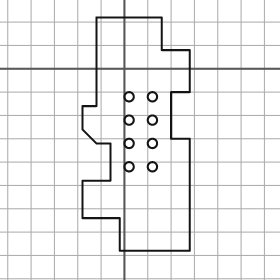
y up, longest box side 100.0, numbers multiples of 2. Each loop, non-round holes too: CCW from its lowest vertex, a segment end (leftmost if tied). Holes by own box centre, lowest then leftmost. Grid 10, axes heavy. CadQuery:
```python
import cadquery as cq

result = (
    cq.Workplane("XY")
    .moveTo(-2.0, -78.0)
    .lineTo(28.0, -78.0)
    .lineTo(28.0, -30.0)
    .lineTo(20.0, -30.0)
    .lineTo(20.0, -10.0)
    .lineTo(28.0, -10.0)
    .lineTo(28.0, 8.0)
    .lineTo(16.0, 8.0)
    .lineTo(16.0, 22.0)
    .lineTo(-12.0, 22.0)
    .lineTo(-12.0, -16.0)
    .lineTo(-18.0, -16.0)
    .lineTo(-18.0, -26.0)
    .lineTo(-12.0, -32.0)
    .lineTo(-6.0, -32.0)
    .lineTo(-6.0, -48.0)
    .lineTo(-18.0, -48.0)
    .lineTo(-18.0, -64.0)
    .lineTo(-2.0, -64.0)
    .close()
    .moveTo(2.0, -42.0)
    .circle(2.0)
    .moveTo(12.0, -42.0)
    .circle(2.0)
    .moveTo(2.0, -32.0)
    .circle(2.0)
    .moveTo(12.0, -32.0)
    .circle(2.0)
    .moveTo(2.0, -22.0)
    .circle(2.0)
    .moveTo(12.0, -22.0)
    .circle(2.0)
    .moveTo(2.0, -12.0)
    .circle(2.0)
    .moveTo(12.0, -12.0)
    .circle(2.0)
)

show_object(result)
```